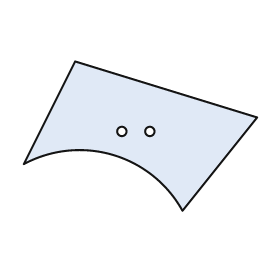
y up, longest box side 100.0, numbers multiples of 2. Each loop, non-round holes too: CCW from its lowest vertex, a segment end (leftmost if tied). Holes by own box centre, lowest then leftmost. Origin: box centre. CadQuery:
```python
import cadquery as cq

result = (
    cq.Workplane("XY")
    .moveTo(18.0, -32.0)
    .lineTo(50.0, 8.0)
    .lineTo(-28.0, 32.0)
    .lineTo(-50.0, -12.0)
    .threePointArc((-12.0, -8.0), (18.0, -32.0))
    .close()
    .moveTo(-8.0, 2.0)
    .circle(2.0)
    .moveTo(4.0, 2.0)
    .circle(2.0)
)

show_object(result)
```